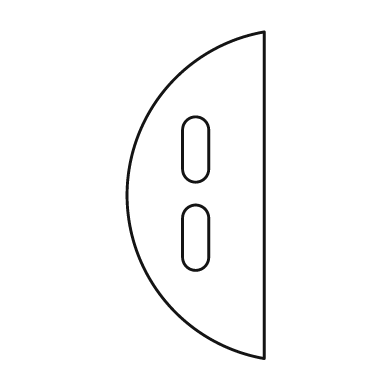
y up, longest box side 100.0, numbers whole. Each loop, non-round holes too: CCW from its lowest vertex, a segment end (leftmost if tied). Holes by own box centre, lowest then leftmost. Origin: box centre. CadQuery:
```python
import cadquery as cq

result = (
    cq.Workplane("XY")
    .moveTo(21.0, -50.0)
    .lineTo(21.0, 50.0)
    .threePointArc((-21.0, 0.0), (21.0, -50.0))
    .close()
    .moveTo(-4.0, -19.0)
    .threePointArc((0.0, -23.0), (4.0, -19.0))
    .lineTo(4.0, -7.0)
    .threePointArc((0.0, -3.0), (-4.0, -7.0))
    .close()
    .moveTo(-4.0, 8.0)
    .threePointArc((0.0, 4.0), (4.0, 8.0))
    .lineTo(4.0, 20.0)
    .threePointArc((0.0, 24.0), (-4.0, 20.0))
    .close()
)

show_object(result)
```